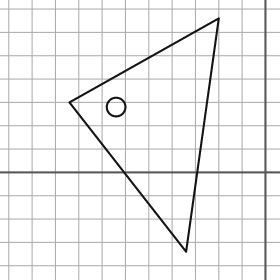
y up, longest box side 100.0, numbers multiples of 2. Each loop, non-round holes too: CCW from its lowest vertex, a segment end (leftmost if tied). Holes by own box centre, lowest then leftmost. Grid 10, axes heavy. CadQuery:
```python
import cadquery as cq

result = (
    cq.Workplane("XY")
    .moveTo(-34.0, -34.0)
    .lineTo(-20.0, 66.0)
    .lineTo(-84.0, 30.0)
    .close()
    .moveTo(-64.0, 28.0)
    .circle(4.0)
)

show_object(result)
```